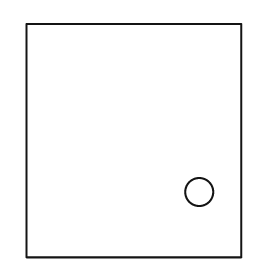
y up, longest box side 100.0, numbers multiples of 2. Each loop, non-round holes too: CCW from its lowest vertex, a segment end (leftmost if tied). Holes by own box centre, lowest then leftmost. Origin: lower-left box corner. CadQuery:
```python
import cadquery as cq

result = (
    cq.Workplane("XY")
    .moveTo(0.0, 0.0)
    .lineTo(92.0, 0.0)
    .lineTo(92.0, 100.0)
    .lineTo(0.0, 100.0)
    .close()
    .moveTo(74.0, 28.0)
    .circle(6.0)
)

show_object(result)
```